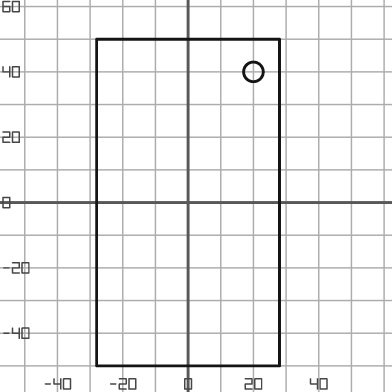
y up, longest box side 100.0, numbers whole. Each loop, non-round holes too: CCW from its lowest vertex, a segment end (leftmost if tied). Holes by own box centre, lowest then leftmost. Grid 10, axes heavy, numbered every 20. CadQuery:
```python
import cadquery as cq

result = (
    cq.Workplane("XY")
    .moveTo(-28.0, -50.0)
    .lineTo(28.0, -50.0)
    .lineTo(28.0, 50.0)
    .lineTo(-28.0, 50.0)
    .close()
    .moveTo(20.0, 40.0)
    .circle(3.0)
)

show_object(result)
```